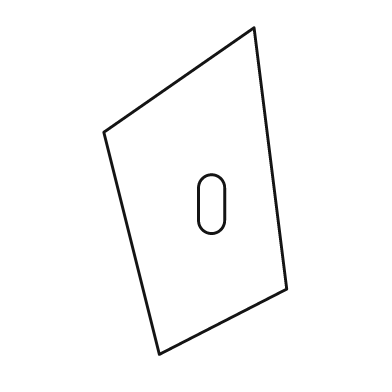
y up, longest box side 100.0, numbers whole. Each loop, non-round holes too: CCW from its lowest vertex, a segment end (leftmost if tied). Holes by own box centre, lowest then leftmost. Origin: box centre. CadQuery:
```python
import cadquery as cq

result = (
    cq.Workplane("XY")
    .moveTo(-11.0, -50.0)
    .lineTo(28.0, -30.0)
    .lineTo(18.0, 50.0)
    .lineTo(-28.0, 18.0)
    .close()
    .moveTo(1.0, -9.0)
    .threePointArc((5.0, -13.0), (9.0, -9.0))
    .lineTo(9.0, 1.0)
    .threePointArc((5.0, 5.0), (1.0, 1.0))
    .close()
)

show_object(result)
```